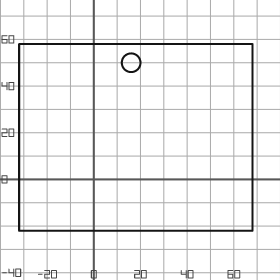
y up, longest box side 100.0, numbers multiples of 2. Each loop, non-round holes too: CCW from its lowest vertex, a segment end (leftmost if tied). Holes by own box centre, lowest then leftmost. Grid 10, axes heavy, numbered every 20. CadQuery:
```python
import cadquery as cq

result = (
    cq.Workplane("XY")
    .moveTo(-32.0, -22.0)
    .lineTo(68.0, -22.0)
    .lineTo(68.0, 58.0)
    .lineTo(-32.0, 58.0)
    .close()
    .moveTo(16.0, 50.0)
    .circle(4.0)
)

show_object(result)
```